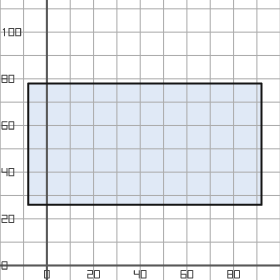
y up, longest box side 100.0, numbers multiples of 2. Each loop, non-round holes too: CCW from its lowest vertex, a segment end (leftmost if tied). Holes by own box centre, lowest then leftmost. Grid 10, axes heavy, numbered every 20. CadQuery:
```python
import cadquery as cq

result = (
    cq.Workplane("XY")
    .moveTo(-8.0, 26.0)
    .lineTo(92.0, 26.0)
    .lineTo(92.0, 78.0)
    .lineTo(-8.0, 78.0)
    .close()
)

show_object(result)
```